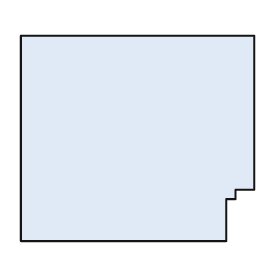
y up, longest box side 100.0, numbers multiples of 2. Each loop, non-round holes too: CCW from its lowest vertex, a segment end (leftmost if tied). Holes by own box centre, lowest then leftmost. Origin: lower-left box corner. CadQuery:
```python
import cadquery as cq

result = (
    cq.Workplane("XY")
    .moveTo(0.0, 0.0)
    .lineTo(88.0, 0.0)
    .lineTo(88.0, 18.0)
    .lineTo(92.0, 18.0)
    .lineTo(92.0, 22.0)
    .lineTo(100.0, 22.0)
    .lineTo(100.0, 88.0)
    .lineTo(0.0, 88.0)
    .close()
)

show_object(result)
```